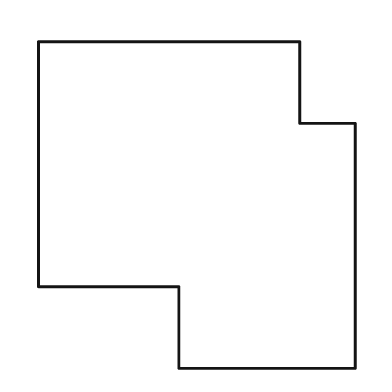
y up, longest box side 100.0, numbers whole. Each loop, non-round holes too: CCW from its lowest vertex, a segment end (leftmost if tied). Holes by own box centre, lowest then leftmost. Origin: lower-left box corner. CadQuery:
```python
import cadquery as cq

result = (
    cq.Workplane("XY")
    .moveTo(43.0, 0.0)
    .lineTo(97.0, 0.0)
    .lineTo(97.0, 75.0)
    .lineTo(80.0, 75.0)
    .lineTo(80.0, 100.0)
    .lineTo(0.0, 100.0)
    .lineTo(0.0, 25.0)
    .lineTo(43.0, 25.0)
    .close()
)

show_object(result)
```